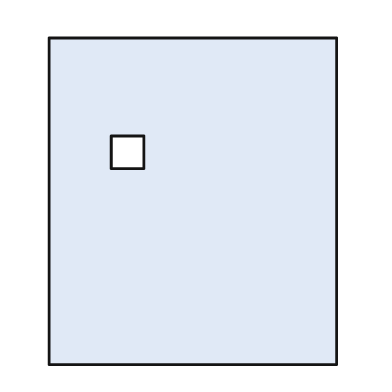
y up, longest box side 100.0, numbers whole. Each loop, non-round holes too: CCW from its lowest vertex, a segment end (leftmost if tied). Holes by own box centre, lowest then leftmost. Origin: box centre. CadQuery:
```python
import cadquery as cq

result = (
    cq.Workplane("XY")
    .moveTo(-44.0, -50.0)
    .lineTo(44.0, -50.0)
    .lineTo(44.0, 50.0)
    .lineTo(-44.0, 50.0)
    .close()
    .moveTo(-25.0, 10.0)
    .lineTo(-15.0, 10.0)
    .lineTo(-15.0, 20.0)
    .lineTo(-25.0, 20.0)
    .close()
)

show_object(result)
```